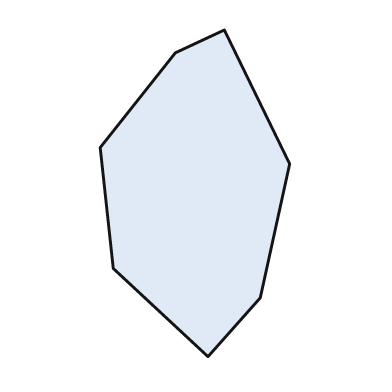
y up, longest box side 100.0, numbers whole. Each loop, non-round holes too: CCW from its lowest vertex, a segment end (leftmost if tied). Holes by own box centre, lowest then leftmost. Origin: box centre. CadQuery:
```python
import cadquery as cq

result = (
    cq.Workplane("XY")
    .moveTo(4.0, -50.0)
    .lineTo(20.0, -32.0)
    .lineTo(29.0, 9.0)
    .lineTo(9.0, 50.0)
    .lineTo(-6.0, 43.0)
    .lineTo(-29.0, 14.0)
    .lineTo(-25.0, -23.0)
    .close()
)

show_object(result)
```